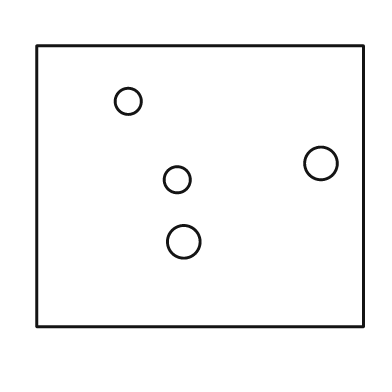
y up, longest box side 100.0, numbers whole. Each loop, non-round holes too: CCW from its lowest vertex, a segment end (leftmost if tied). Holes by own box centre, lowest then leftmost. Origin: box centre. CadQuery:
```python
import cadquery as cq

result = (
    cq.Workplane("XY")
    .moveTo(-50.0, -43.0)
    .lineTo(50.0, -43.0)
    .lineTo(50.0, 43.0)
    .lineTo(-50.0, 43.0)
    .close()
    .moveTo(-5.0, -17.0)
    .circle(5.0)
    .moveTo(-7.0, 2.0)
    .circle(4.0)
    .moveTo(37.0, 7.0)
    .circle(5.0)
    .moveTo(-22.0, 26.0)
    .circle(4.0)
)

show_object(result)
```